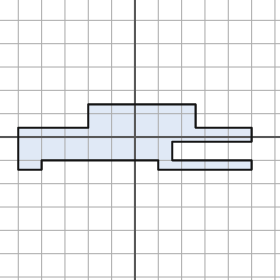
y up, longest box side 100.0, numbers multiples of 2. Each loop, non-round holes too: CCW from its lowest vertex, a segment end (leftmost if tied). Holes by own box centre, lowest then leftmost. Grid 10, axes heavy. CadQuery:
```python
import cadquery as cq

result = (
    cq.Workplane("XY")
    .moveTo(-50.0, -14.0)
    .lineTo(-40.0, -14.0)
    .lineTo(-40.0, -10.0)
    .lineTo(10.0, -10.0)
    .lineTo(10.0, -14.0)
    .lineTo(50.0, -14.0)
    .lineTo(50.0, -10.0)
    .lineTo(16.0, -10.0)
    .lineTo(16.0, -2.0)
    .lineTo(50.0, -2.0)
    .lineTo(50.0, 4.0)
    .lineTo(26.0, 4.0)
    .lineTo(26.0, 14.0)
    .lineTo(-20.0, 14.0)
    .lineTo(-20.0, 4.0)
    .lineTo(-50.0, 4.0)
    .close()
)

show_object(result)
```